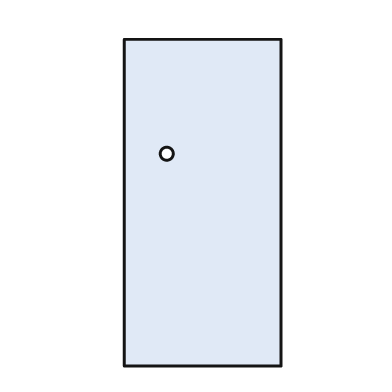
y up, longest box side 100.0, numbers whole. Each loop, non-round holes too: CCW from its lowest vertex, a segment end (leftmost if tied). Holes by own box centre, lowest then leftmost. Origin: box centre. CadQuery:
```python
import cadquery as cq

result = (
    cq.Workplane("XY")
    .moveTo(-24.0, -50.0)
    .lineTo(24.0, -50.0)
    .lineTo(24.0, 50.0)
    .lineTo(-24.0, 50.0)
    .close()
    .moveTo(-11.0, 15.0)
    .circle(2.0)
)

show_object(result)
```